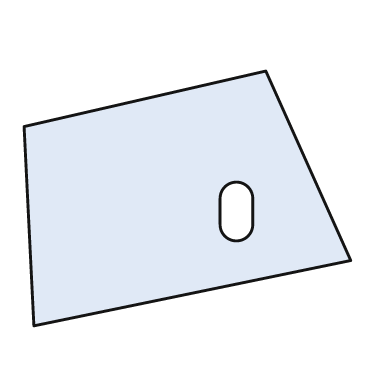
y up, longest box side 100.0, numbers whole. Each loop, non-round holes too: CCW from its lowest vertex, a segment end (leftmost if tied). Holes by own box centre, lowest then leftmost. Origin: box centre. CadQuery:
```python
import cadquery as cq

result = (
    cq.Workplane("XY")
    .moveTo(-47.0, -39.0)
    .lineTo(50.0, -19.0)
    .lineTo(24.0, 39.0)
    .lineTo(-50.0, 22.0)
    .close()
    .moveTo(10.0, -8.0)
    .threePointArc((15.0, -13.0), (20.0, -8.0))
    .lineTo(20.0, 0.0)
    .threePointArc((15.0, 5.0), (10.0, 0.0))
    .close()
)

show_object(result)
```